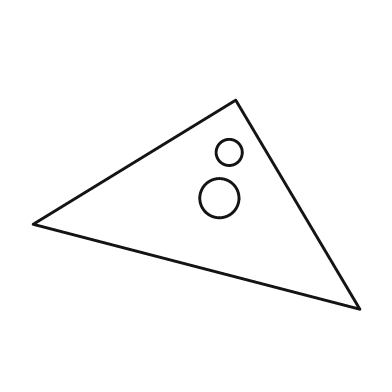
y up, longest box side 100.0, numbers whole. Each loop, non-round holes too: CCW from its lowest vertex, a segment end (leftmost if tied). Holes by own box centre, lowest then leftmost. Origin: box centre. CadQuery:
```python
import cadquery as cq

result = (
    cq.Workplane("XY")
    .moveTo(50.0, -32.0)
    .lineTo(12.0, 32.0)
    .lineTo(-50.0, -6.0)
    .close()
    .moveTo(7.0, 2.0)
    .circle(6.0)
    .moveTo(10.0, 16.0)
    .circle(4.0)
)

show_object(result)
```